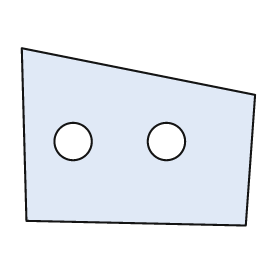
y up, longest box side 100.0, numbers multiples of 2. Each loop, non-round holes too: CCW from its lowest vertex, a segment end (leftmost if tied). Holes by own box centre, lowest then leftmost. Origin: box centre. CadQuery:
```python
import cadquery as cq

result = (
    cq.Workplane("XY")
    .moveTo(46.0, -38.0)
    .lineTo(50.0, 18.0)
    .lineTo(-50.0, 38.0)
    .lineTo(-48.0, -36.0)
    .close()
    .moveTo(-28.0, -2.0)
    .circle(8.0)
    .moveTo(12.0, -2.0)
    .circle(8.0)
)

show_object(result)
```